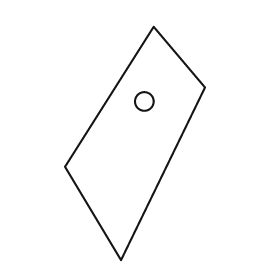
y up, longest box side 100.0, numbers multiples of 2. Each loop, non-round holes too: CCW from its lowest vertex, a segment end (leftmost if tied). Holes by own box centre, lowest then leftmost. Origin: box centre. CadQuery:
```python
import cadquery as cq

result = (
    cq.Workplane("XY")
    .moveTo(-6.0, -50.0)
    .lineTo(30.0, 24.0)
    .lineTo(8.0, 50.0)
    .lineTo(-30.0, -10.0)
    .close()
    .moveTo(4.0, 18.0)
    .circle(4.0)
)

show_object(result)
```